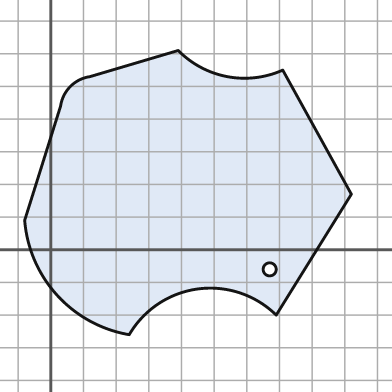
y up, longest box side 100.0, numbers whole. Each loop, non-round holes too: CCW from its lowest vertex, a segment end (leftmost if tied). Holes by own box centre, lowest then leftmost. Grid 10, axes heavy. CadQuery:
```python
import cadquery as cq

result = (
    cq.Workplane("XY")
    .moveTo(24.0, -26.0)
    .threePointArc((45.0, -12.0), (69.0, -20.0))
    .lineTo(92.0, 17.0)
    .lineTo(71.0, 55.0)
    .threePointArc((54.0, 53.0), (39.0, 61.0))
    .lineTo(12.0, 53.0)
    .threePointArc((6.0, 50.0), (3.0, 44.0))
    .lineTo(-8.0, 9.0)
    .threePointArc((2.0, -14.0), (24.0, -26.0))
    .close()
    .moveTo(67.0, -6.0)
    .circle(2.0)
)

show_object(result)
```